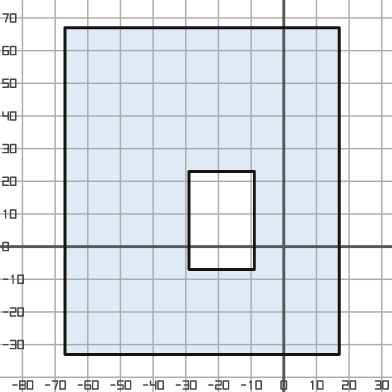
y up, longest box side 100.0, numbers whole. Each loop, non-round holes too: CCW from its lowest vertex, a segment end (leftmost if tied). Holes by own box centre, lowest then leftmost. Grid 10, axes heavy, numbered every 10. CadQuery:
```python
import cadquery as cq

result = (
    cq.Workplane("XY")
    .moveTo(-67.0, -33.0)
    .lineTo(17.0, -33.0)
    .lineTo(17.0, 67.0)
    .lineTo(-67.0, 67.0)
    .close()
    .moveTo(-29.0, -7.0)
    .lineTo(-9.0, -7.0)
    .lineTo(-9.0, 23.0)
    .lineTo(-29.0, 23.0)
    .close()
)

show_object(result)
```